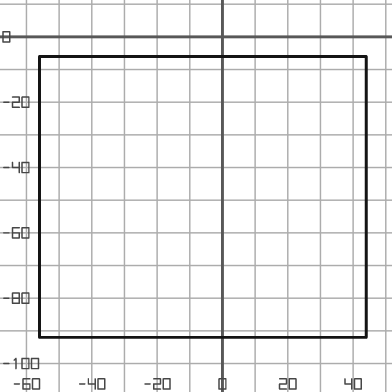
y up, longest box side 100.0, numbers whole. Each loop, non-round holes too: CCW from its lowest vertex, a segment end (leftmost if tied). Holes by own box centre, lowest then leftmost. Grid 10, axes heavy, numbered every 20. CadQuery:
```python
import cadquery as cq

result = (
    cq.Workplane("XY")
    .moveTo(-56.0, -92.0)
    .lineTo(44.0, -92.0)
    .lineTo(44.0, -6.0)
    .lineTo(-56.0, -6.0)
    .close()
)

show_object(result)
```